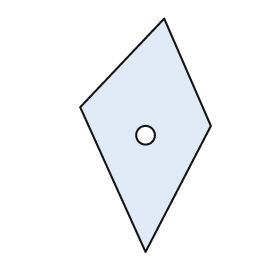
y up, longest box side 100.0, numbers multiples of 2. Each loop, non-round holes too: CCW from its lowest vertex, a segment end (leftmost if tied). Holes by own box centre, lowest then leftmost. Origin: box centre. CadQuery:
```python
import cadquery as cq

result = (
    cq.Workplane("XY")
    .moveTo(0.0, -50.0)
    .lineTo(28.0, 4.0)
    .lineTo(8.0, 50.0)
    .lineTo(-28.0, 12.0)
    .close()
    .moveTo(0.0, 0.0)
    .circle(4.0)
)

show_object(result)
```